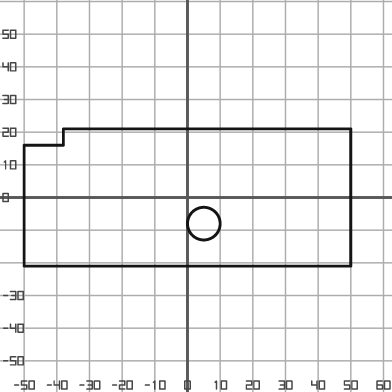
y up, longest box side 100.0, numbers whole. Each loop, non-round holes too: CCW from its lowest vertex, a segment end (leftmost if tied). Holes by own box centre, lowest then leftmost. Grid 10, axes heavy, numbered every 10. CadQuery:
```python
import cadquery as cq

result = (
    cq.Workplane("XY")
    .moveTo(-50.0, -21.0)
    .lineTo(50.0, -21.0)
    .lineTo(50.0, 21.0)
    .lineTo(-38.0, 21.0)
    .lineTo(-38.0, 16.0)
    .lineTo(-50.0, 16.0)
    .close()
    .moveTo(5.0, -8.0)
    .circle(5.0)
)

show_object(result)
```